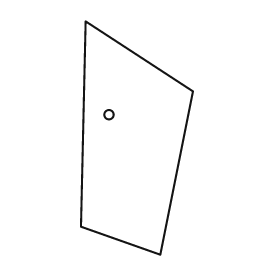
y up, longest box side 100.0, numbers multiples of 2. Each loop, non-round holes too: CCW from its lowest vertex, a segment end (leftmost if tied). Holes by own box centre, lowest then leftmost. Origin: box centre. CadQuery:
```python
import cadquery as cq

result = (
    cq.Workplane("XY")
    .moveTo(10.0, -50.0)
    .lineTo(24.0, 20.0)
    .lineTo(-22.0, 50.0)
    .lineTo(-24.0, -38.0)
    .close()
    .moveTo(-12.0, 10.0)
    .circle(2.0)
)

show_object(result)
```